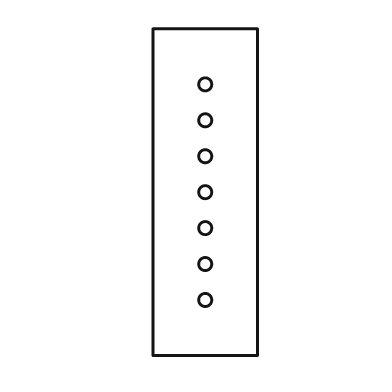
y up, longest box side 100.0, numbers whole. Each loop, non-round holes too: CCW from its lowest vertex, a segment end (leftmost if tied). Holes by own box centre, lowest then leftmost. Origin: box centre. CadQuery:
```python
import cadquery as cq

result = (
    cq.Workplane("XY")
    .moveTo(-16.0, -50.0)
    .lineTo(16.0, -50.0)
    .lineTo(16.0, 50.0)
    .lineTo(-16.0, 50.0)
    .close()
    .moveTo(0.0, -33.0)
    .circle(2.0)
    .moveTo(0.0, -22.0)
    .circle(2.0)
    .moveTo(0.0, -11.0)
    .circle(2.0)
    .moveTo(0.0, 0.0)
    .circle(2.0)
    .moveTo(0.0, 11.0)
    .circle(2.0)
    .moveTo(0.0, 22.0)
    .circle(2.0)
    .moveTo(0.0, 33.0)
    .circle(2.0)
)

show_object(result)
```